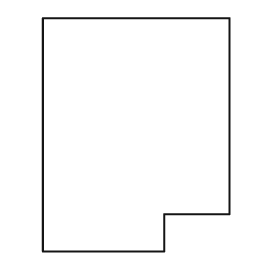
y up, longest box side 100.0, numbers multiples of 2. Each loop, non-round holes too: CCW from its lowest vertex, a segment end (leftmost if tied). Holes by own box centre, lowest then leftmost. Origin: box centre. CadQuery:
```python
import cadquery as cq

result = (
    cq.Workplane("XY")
    .moveTo(-40.0, -50.0)
    .lineTo(12.0, -50.0)
    .lineTo(12.0, -34.0)
    .lineTo(40.0, -34.0)
    .lineTo(40.0, 50.0)
    .lineTo(-40.0, 50.0)
    .close()
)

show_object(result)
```